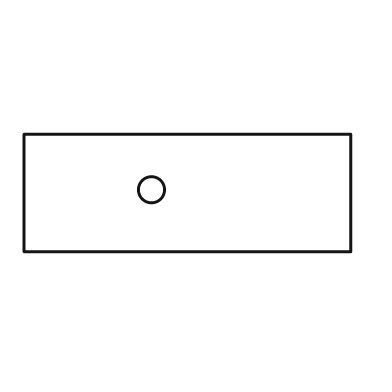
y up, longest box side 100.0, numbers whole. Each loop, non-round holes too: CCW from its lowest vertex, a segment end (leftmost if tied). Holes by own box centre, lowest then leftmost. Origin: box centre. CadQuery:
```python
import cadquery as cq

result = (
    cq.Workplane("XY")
    .moveTo(-50.0, -18.0)
    .lineTo(50.0, -18.0)
    .lineTo(50.0, 18.0)
    .lineTo(-50.0, 18.0)
    .close()
    .moveTo(-11.0, 1.0)
    .circle(4.0)
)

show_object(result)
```